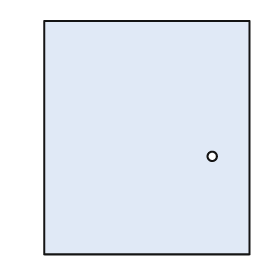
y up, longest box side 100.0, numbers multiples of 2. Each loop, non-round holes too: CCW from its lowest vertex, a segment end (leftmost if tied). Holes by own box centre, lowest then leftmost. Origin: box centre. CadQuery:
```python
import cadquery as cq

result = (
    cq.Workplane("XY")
    .moveTo(-44.0, -50.0)
    .lineTo(44.0, -50.0)
    .lineTo(44.0, 50.0)
    .lineTo(-44.0, 50.0)
    .close()
    .moveTo(28.0, -8.0)
    .circle(2.0)
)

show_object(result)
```